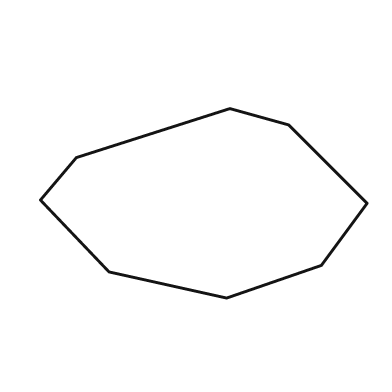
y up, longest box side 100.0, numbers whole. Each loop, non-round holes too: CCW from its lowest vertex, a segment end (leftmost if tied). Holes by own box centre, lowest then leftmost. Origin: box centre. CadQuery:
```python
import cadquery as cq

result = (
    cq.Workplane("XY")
    .moveTo(7.0, -29.0)
    .lineTo(36.0, -19.0)
    .lineTo(50.0, 0.0)
    .lineTo(26.0, 24.0)
    .lineTo(8.0, 29.0)
    .lineTo(-39.0, 14.0)
    .lineTo(-50.0, 1.0)
    .lineTo(-29.0, -21.0)
    .close()
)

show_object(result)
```